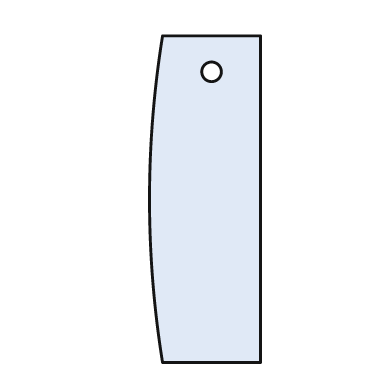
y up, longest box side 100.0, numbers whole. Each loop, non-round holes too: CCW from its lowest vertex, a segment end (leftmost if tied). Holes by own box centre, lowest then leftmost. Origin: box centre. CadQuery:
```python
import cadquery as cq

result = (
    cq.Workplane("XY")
    .moveTo(-13.0, -50.0)
    .lineTo(17.0, -50.0)
    .lineTo(17.0, 50.0)
    .lineTo(-13.0, 50.0)
    .threePointArc((-17.0, 0.0), (-13.0, -50.0))
    .close()
    .moveTo(2.0, 39.0)
    .circle(3.0)
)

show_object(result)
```